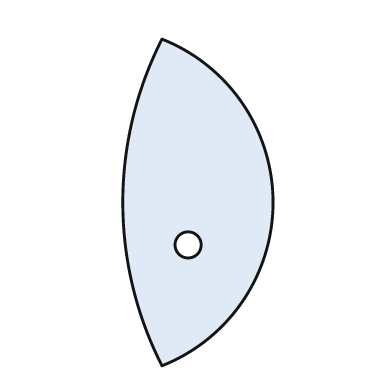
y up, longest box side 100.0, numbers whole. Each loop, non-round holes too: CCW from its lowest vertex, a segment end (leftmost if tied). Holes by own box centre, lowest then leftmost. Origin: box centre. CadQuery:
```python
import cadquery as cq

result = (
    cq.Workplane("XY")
    .moveTo(-11.0, -50.0)
    .threePointArc((23.0, 0.0), (-11.0, 50.0))
    .threePointArc((-23.0, 0.0), (-11.0, -50.0))
    .close()
    .moveTo(-3.0, -13.0)
    .circle(4.0)
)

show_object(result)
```